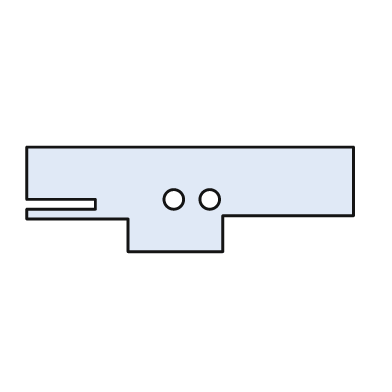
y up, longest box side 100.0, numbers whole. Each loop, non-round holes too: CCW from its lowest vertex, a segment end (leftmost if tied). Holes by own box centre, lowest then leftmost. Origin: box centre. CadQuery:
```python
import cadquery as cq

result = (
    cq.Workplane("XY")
    .moveTo(-19.0, -16.0)
    .lineTo(10.0, -16.0)
    .lineTo(10.0, -5.0)
    .lineTo(50.0, -5.0)
    .lineTo(50.0, 16.0)
    .lineTo(-50.0, 16.0)
    .lineTo(-50.0, 0.0)
    .lineTo(-29.0, 0.0)
    .lineTo(-29.0, -3.0)
    .lineTo(-50.0, -3.0)
    .lineTo(-50.0, -6.0)
    .lineTo(-19.0, -6.0)
    .close()
    .moveTo(-5.0, 0.0)
    .circle(3.0)
    .moveTo(6.0, 0.0)
    .circle(3.0)
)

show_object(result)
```